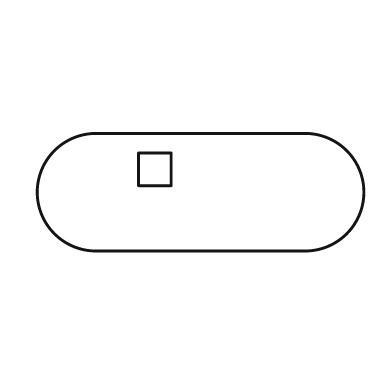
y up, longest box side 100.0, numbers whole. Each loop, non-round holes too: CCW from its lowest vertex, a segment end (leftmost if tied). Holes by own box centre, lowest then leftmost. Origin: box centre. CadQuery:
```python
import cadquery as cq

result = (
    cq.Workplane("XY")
    .moveTo(-32.0, -18.0)
    .lineTo(32.0, -18.0)
    .threePointArc((50.0, 0.0), (32.0, 18.0))
    .lineTo(-32.0, 18.0)
    .threePointArc((-50.0, 0.0), (-32.0, -18.0))
    .close()
    .moveTo(-19.0, 2.0)
    .lineTo(-9.0, 2.0)
    .lineTo(-9.0, 12.0)
    .lineTo(-19.0, 12.0)
    .close()
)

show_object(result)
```